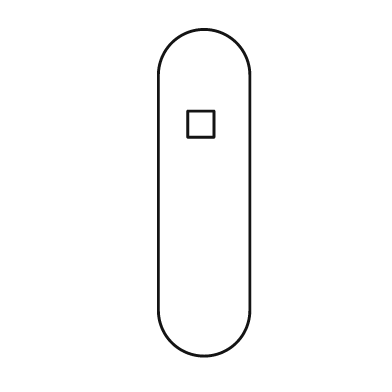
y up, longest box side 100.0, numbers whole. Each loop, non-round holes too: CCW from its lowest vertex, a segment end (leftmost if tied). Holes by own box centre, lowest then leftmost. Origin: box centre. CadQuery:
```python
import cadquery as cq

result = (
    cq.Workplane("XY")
    .moveTo(-14.0, -36.0)
    .threePointArc((0.0, -50.0), (14.0, -36.0))
    .lineTo(14.0, 36.0)
    .threePointArc((0.0, 50.0), (-14.0, 36.0))
    .close()
    .moveTo(-5.0, 17.0)
    .lineTo(3.0, 17.0)
    .lineTo(3.0, 25.0)
    .lineTo(-5.0, 25.0)
    .close()
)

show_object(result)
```